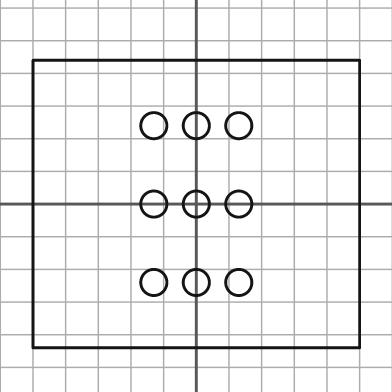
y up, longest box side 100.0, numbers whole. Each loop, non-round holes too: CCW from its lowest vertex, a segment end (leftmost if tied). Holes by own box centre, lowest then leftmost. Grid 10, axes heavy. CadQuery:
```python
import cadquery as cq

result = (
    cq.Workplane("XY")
    .moveTo(-50.0, -44.0)
    .lineTo(50.0, -44.0)
    .lineTo(50.0, 44.0)
    .lineTo(-50.0, 44.0)
    .close()
    .moveTo(-13.0, -24.0)
    .circle(4.0)
    .moveTo(0.0, -24.0)
    .circle(4.0)
    .moveTo(13.0, -24.0)
    .circle(4.0)
    .moveTo(-13.0, 0.0)
    .circle(4.0)
    .moveTo(0.0, 0.0)
    .circle(4.0)
    .moveTo(13.0, 0.0)
    .circle(4.0)
    .moveTo(-13.0, 24.0)
    .circle(4.0)
    .moveTo(0.0, 24.0)
    .circle(4.0)
    .moveTo(13.0, 24.0)
    .circle(4.0)
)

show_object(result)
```